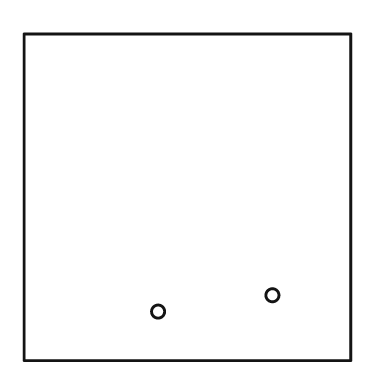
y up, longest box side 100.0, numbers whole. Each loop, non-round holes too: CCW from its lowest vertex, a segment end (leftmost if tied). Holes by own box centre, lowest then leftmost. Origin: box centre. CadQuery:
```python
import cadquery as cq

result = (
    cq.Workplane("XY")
    .moveTo(-50.0, -50.0)
    .lineTo(50.0, -50.0)
    .lineTo(50.0, 50.0)
    .lineTo(-50.0, 50.0)
    .close()
    .moveTo(-9.0, -35.0)
    .circle(2.0)
    .moveTo(26.0, -30.0)
    .circle(2.0)
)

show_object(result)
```